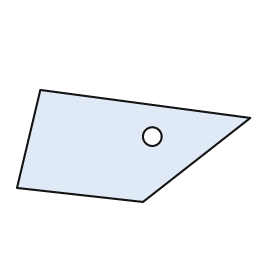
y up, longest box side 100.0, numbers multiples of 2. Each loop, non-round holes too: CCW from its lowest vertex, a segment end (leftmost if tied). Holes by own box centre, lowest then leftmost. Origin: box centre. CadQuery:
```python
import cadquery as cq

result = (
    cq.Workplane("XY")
    .moveTo(4.0, -24.0)
    .lineTo(50.0, 12.0)
    .lineTo(-40.0, 24.0)
    .lineTo(-50.0, -18.0)
    .close()
    .moveTo(8.0, 4.0)
    .circle(4.0)
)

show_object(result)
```